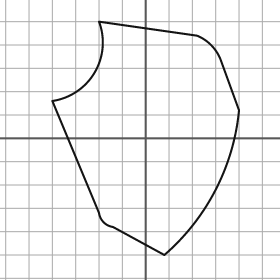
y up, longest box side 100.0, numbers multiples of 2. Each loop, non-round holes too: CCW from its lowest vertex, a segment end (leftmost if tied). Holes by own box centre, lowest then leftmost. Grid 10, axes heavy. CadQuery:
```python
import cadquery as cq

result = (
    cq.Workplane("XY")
    .moveTo(8.0, -50.0)
    .threePointArc((30.0, -22.0), (40.0, 12.0))
    .lineTo(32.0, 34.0)
    .threePointArc((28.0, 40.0), (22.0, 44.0))
    .lineTo(-20.0, 50.0)
    .threePointArc((-22.0, 28.0), (-40.0, 16.0))
    .lineTo(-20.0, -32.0)
    .threePointArc((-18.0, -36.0), (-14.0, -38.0))
    .close()
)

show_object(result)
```